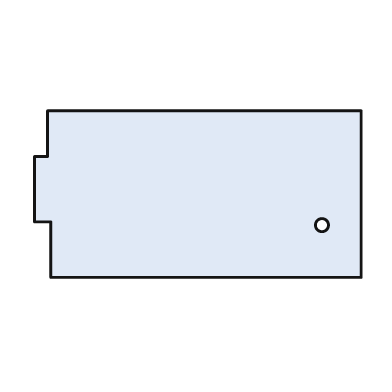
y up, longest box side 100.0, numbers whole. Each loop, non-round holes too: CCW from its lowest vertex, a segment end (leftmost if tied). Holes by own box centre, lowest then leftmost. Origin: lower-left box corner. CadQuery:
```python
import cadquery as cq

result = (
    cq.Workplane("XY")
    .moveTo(5.0, 0.0)
    .lineTo(100.0, 0.0)
    .lineTo(100.0, 51.0)
    .lineTo(4.0, 51.0)
    .lineTo(4.0, 37.0)
    .lineTo(0.0, 37.0)
    .lineTo(0.0, 17.0)
    .lineTo(5.0, 17.0)
    .close()
    .moveTo(88.0, 16.0)
    .circle(2.0)
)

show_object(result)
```